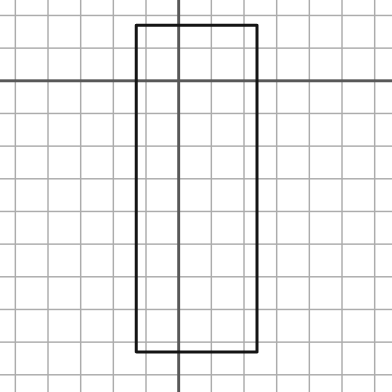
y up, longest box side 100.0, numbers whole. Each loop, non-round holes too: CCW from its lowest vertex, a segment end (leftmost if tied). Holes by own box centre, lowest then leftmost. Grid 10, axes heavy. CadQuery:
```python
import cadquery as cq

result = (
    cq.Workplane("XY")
    .moveTo(-13.0, -83.0)
    .lineTo(24.0, -83.0)
    .lineTo(24.0, 17.0)
    .lineTo(-13.0, 17.0)
    .close()
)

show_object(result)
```